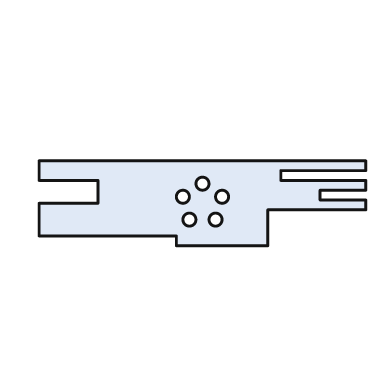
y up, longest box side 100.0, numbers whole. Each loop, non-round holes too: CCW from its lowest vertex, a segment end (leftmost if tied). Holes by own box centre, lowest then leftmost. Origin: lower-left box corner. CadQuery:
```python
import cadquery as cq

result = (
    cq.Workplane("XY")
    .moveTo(42.0, 0.0)
    .lineTo(70.0, 0.0)
    .lineTo(70.0, 11.0)
    .lineTo(100.0, 11.0)
    .lineTo(100.0, 14.0)
    .lineTo(86.0, 14.0)
    .lineTo(86.0, 17.0)
    .lineTo(100.0, 17.0)
    .lineTo(100.0, 20.0)
    .lineTo(74.0, 20.0)
    .lineTo(74.0, 23.0)
    .lineTo(100.0, 23.0)
    .lineTo(100.0, 26.0)
    .lineTo(0.0, 26.0)
    .lineTo(0.0, 20.0)
    .lineTo(18.0, 20.0)
    .lineTo(18.0, 13.0)
    .lineTo(0.0, 13.0)
    .lineTo(0.0, 3.0)
    .lineTo(42.0, 3.0)
    .close()
    .moveTo(46.0, 8.0)
    .circle(2.0)
    .moveTo(54.0, 8.0)
    .circle(2.0)
    .moveTo(44.0, 15.0)
    .circle(2.0)
    .moveTo(56.0, 15.0)
    .circle(2.0)
    .moveTo(50.0, 19.0)
    .circle(2.0)
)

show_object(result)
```